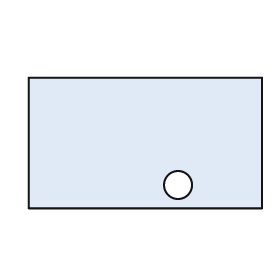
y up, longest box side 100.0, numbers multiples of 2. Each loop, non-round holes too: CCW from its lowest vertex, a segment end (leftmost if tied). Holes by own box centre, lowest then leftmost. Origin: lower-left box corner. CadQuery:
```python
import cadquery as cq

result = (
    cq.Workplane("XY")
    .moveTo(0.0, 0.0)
    .lineTo(100.0, 0.0)
    .lineTo(100.0, 56.0)
    .lineTo(0.0, 56.0)
    .close()
    .moveTo(64.0, 10.0)
    .circle(6.0)
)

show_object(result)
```